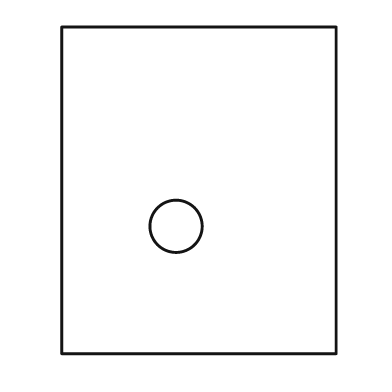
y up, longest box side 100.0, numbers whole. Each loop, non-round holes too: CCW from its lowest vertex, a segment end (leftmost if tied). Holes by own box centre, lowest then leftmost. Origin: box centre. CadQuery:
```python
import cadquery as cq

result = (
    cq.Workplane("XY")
    .moveTo(-42.0, -50.0)
    .lineTo(42.0, -50.0)
    .lineTo(42.0, 50.0)
    .lineTo(-42.0, 50.0)
    .close()
    .moveTo(-7.0, -11.0)
    .circle(8.0)
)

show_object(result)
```